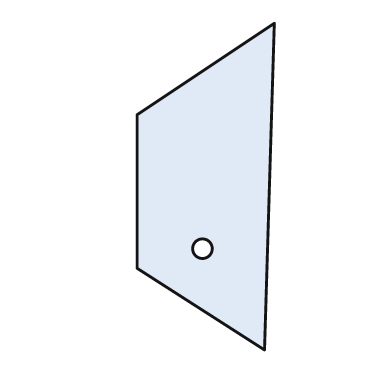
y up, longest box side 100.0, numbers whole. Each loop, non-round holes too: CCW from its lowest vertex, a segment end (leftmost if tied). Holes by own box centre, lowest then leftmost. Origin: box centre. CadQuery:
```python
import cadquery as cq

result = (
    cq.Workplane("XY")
    .moveTo(18.0, -50.0)
    .lineTo(21.0, 50.0)
    .lineTo(-21.0, 22.0)
    .lineTo(-21.0, -25.0)
    .close()
    .moveTo(-1.0, -19.0)
    .circle(3.0)
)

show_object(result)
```